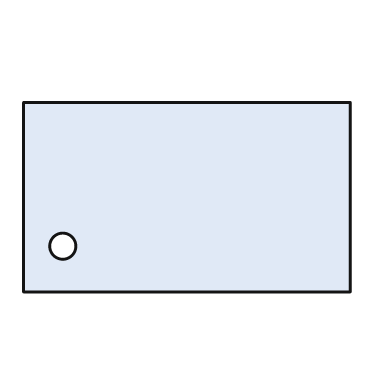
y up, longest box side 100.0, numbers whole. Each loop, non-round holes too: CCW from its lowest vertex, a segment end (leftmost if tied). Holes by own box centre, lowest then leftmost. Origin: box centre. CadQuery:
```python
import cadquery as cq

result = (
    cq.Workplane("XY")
    .moveTo(-50.0, -29.0)
    .lineTo(50.0, -29.0)
    .lineTo(50.0, 29.0)
    .lineTo(-50.0, 29.0)
    .close()
    .moveTo(-38.0, -15.0)
    .circle(4.0)
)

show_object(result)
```